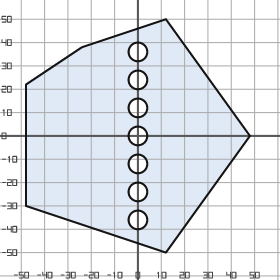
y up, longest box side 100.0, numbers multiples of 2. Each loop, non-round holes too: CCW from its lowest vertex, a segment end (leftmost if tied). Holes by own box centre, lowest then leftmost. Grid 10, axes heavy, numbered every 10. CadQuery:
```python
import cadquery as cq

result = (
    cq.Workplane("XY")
    .moveTo(12.0, -50.0)
    .lineTo(48.0, 0.0)
    .lineTo(12.0, 50.0)
    .lineTo(-24.0, 38.0)
    .lineTo(-48.0, 22.0)
    .lineTo(-48.0, -30.0)
    .close()
    .moveTo(0.0, -36.0)
    .circle(4.0)
    .moveTo(0.0, -24.0)
    .circle(4.0)
    .moveTo(0.0, -12.0)
    .circle(4.0)
    .moveTo(0.0, 0.0)
    .circle(4.0)
    .moveTo(0.0, 12.0)
    .circle(4.0)
    .moveTo(0.0, 24.0)
    .circle(4.0)
    .moveTo(0.0, 36.0)
    .circle(4.0)
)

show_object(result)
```